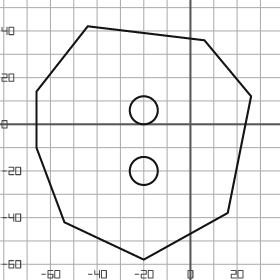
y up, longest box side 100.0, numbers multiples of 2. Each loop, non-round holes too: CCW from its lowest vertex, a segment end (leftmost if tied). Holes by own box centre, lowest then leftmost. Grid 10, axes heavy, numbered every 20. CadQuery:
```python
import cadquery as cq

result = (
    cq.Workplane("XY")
    .moveTo(-20.0, -58.0)
    .lineTo(16.0, -38.0)
    .lineTo(26.0, 12.0)
    .lineTo(6.0, 36.0)
    .lineTo(-44.0, 42.0)
    .lineTo(-66.0, 14.0)
    .lineTo(-66.0, -10.0)
    .lineTo(-54.0, -42.0)
    .close()
    .moveTo(-20.0, -20.0)
    .circle(6.0)
    .moveTo(-20.0, 6.0)
    .circle(6.0)
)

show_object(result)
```